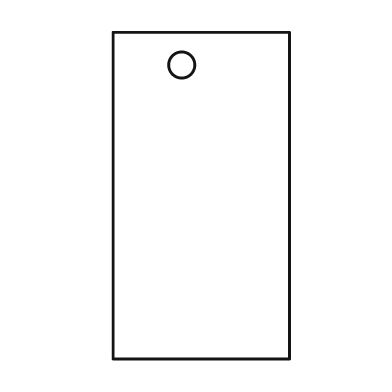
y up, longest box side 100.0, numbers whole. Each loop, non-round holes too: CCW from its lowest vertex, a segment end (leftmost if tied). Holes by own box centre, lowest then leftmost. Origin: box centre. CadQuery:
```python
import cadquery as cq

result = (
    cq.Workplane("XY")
    .moveTo(-27.0, -50.0)
    .lineTo(27.0, -50.0)
    .lineTo(27.0, 50.0)
    .lineTo(-27.0, 50.0)
    .close()
    .moveTo(-6.0, 40.0)
    .circle(4.0)
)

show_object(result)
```